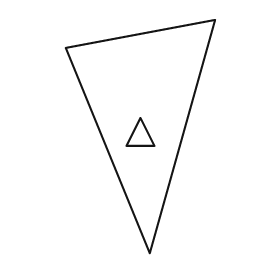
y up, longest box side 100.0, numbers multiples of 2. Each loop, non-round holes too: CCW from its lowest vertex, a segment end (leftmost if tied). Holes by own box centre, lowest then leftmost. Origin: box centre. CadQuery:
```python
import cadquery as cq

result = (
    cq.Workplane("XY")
    .moveTo(4.0, -50.0)
    .lineTo(32.0, 50.0)
    .lineTo(-32.0, 38.0)
    .close()
    .moveTo(-6.0, -4.0)
    .lineTo(6.0, -4.0)
    .lineTo(0.0, 8.0)
    .close()
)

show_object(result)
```